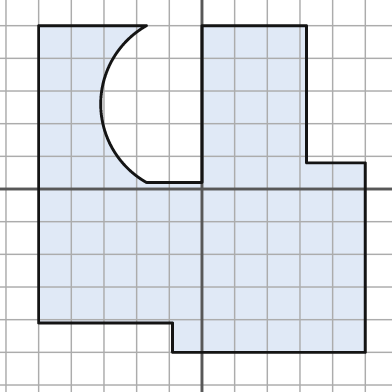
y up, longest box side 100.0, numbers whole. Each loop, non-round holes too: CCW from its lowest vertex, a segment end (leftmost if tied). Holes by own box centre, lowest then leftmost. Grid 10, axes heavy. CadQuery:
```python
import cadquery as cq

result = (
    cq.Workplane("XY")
    .moveTo(-9.0, -50.0)
    .lineTo(50.0, -50.0)
    .lineTo(50.0, 8.0)
    .lineTo(32.0, 8.0)
    .lineTo(32.0, 50.0)
    .lineTo(0.0, 50.0)
    .lineTo(0.0, 2.0)
    .lineTo(-17.0, 2.0)
    .threePointArc((-31.0, 26.0), (-17.0, 50.0))
    .lineTo(-50.0, 50.0)
    .lineTo(-50.0, -41.0)
    .lineTo(-9.0, -41.0)
    .close()
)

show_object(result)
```